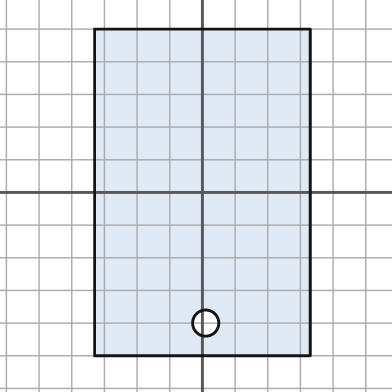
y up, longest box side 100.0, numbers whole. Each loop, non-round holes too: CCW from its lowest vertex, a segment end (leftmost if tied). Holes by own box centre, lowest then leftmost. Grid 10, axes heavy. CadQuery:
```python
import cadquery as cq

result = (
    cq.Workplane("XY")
    .moveTo(-33.0, -50.0)
    .lineTo(33.0, -50.0)
    .lineTo(33.0, 50.0)
    .lineTo(-33.0, 50.0)
    .close()
    .moveTo(1.0, -40.0)
    .circle(4.0)
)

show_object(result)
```